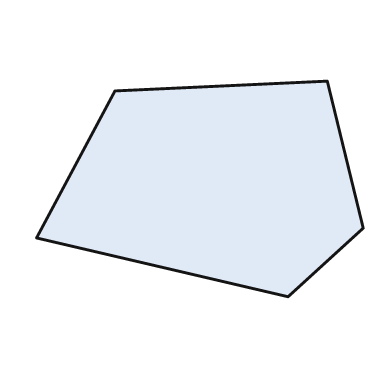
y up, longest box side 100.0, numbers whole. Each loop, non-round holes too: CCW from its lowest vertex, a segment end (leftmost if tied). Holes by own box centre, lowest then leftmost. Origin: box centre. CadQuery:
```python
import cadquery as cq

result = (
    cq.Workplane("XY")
    .moveTo(27.0, -33.0)
    .lineTo(50.0, -12.0)
    .lineTo(39.0, 33.0)
    .lineTo(-26.0, 30.0)
    .lineTo(-50.0, -15.0)
    .close()
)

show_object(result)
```